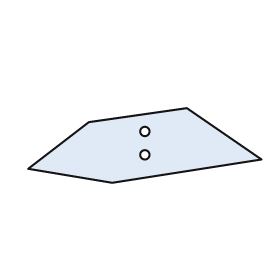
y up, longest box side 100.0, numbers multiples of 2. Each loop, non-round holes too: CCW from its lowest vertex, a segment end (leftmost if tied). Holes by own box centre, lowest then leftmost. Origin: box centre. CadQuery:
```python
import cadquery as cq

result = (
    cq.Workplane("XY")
    .moveTo(-14.0, -16.0)
    .lineTo(50.0, -6.0)
    .lineTo(18.0, 16.0)
    .lineTo(-24.0, 10.0)
    .lineTo(-50.0, -10.0)
    .close()
    .moveTo(0.0, -4.0)
    .circle(2.0)
    .moveTo(0.0, 6.0)
    .circle(2.0)
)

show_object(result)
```